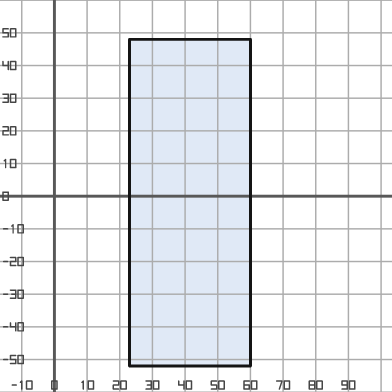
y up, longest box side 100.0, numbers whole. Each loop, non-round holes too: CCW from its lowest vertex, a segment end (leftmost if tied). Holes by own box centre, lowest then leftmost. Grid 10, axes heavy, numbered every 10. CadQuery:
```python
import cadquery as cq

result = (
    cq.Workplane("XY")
    .moveTo(23.0, -52.0)
    .lineTo(60.0, -52.0)
    .lineTo(60.0, 48.0)
    .lineTo(23.0, 48.0)
    .close()
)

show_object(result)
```